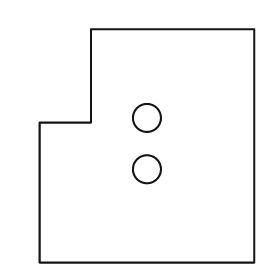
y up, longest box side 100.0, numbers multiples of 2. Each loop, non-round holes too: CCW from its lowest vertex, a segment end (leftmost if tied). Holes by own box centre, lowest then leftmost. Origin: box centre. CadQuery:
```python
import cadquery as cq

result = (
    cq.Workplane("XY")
    .moveTo(-46.0, -50.0)
    .lineTo(46.0, -50.0)
    .lineTo(46.0, 50.0)
    .lineTo(-24.0, 50.0)
    .lineTo(-24.0, 10.0)
    .lineTo(-46.0, 10.0)
    .close()
    .moveTo(0.0, -10.0)
    .circle(6.0)
    .moveTo(0.0, 12.0)
    .circle(6.0)
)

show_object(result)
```